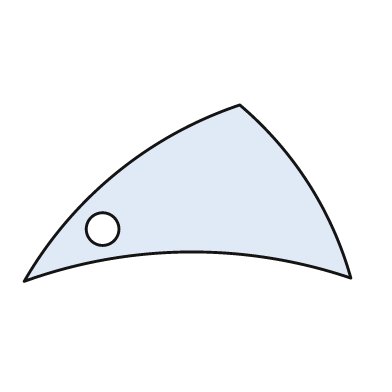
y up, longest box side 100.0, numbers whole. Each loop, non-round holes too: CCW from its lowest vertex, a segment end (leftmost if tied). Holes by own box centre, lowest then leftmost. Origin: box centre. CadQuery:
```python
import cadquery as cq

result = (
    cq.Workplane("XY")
    .moveTo(-50.0, -27.0)
    .threePointArc((0.0, -18.0), (50.0, -26.0))
    .threePointArc((37.0, 3.0), (16.0, 27.0))
    .threePointArc((-22.0, 6.0), (-50.0, -27.0))
    .close()
    .moveTo(-26.0, -11.0)
    .circle(5.0)
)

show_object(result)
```